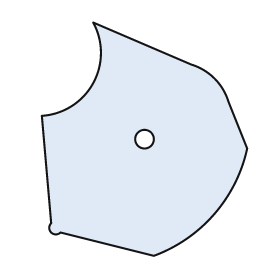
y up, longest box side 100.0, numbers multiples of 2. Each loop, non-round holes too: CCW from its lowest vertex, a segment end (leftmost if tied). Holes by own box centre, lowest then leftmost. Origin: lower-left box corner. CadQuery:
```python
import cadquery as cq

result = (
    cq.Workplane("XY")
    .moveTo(48.0, 0.0)
    .threePointArc((74.0, 18.0), (88.0, 46.0))
    .lineTo(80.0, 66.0)
    .threePointArc((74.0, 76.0), (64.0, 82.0))
    .lineTo(22.0, 100.0)
    .threePointArc((22.0, 74.0), (0.0, 60.0))
    .lineTo(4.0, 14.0)
    .threePointArc((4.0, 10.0), (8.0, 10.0))
    .close()
    .moveTo(44.0, 50.0)
    .circle(4.0)
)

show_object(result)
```